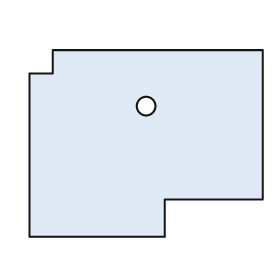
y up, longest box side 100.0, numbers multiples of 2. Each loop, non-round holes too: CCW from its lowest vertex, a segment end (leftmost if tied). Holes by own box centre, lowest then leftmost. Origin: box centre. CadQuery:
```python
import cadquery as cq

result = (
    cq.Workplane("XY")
    .moveTo(-50.0, -40.0)
    .lineTo(8.0, -40.0)
    .lineTo(8.0, -24.0)
    .lineTo(50.0, -24.0)
    .lineTo(50.0, 40.0)
    .lineTo(-40.0, 40.0)
    .lineTo(-40.0, 30.0)
    .lineTo(-50.0, 30.0)
    .close()
    .moveTo(0.0, 16.0)
    .circle(4.0)
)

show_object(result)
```